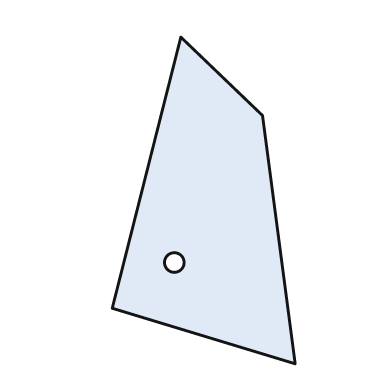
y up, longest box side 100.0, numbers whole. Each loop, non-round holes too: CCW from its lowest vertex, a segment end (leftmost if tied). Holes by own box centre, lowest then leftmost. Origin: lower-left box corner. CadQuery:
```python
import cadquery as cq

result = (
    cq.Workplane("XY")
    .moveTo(56.0, 0.0)
    .lineTo(46.0, 76.0)
    .lineTo(21.0, 100.0)
    .lineTo(0.0, 17.0)
    .close()
    .moveTo(19.0, 31.0)
    .circle(3.0)
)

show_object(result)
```